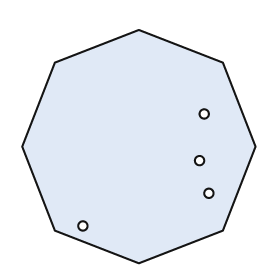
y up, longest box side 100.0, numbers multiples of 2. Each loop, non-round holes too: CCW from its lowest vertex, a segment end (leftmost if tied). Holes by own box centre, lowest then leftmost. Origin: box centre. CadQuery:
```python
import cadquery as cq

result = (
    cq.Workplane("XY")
    .moveTo(0.0, -50.0)
    .lineTo(36.0, -36.0)
    .lineTo(50.0, 0.0)
    .lineTo(36.0, 36.0)
    .lineTo(0.0, 50.0)
    .lineTo(-36.0, 36.0)
    .lineTo(-50.0, 0.0)
    .lineTo(-36.0, -36.0)
    .close()
    .moveTo(-24.0, -34.0)
    .circle(2.0)
    .moveTo(30.0, -20.0)
    .circle(2.0)
    .moveTo(26.0, -6.0)
    .circle(2.0)
    .moveTo(28.0, 14.0)
    .circle(2.0)
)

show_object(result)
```